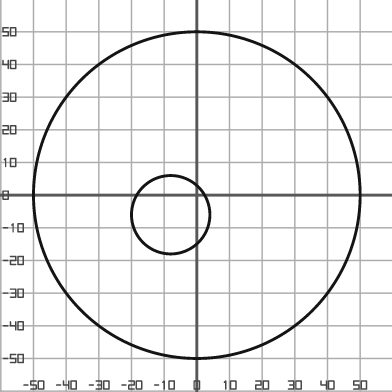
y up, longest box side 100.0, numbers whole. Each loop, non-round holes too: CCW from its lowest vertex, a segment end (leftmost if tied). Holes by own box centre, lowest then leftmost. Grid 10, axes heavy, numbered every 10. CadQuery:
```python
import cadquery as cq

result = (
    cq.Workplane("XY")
    .moveTo(0.0, 0.0)
    .circle(50.0)
    .moveTo(-8.0, -6.0)
    .circle(12.0)
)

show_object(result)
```